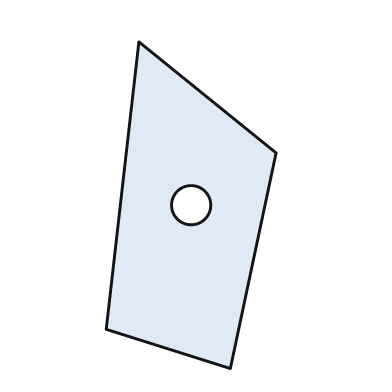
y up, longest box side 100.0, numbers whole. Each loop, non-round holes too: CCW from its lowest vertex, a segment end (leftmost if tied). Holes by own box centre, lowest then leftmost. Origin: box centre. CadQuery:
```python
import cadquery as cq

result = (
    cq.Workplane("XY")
    .moveTo(12.0, -50.0)
    .lineTo(26.0, 16.0)
    .lineTo(-16.0, 50.0)
    .lineTo(-26.0, -38.0)
    .close()
    .moveTo(0.0, 0.0)
    .circle(6.0)
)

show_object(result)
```